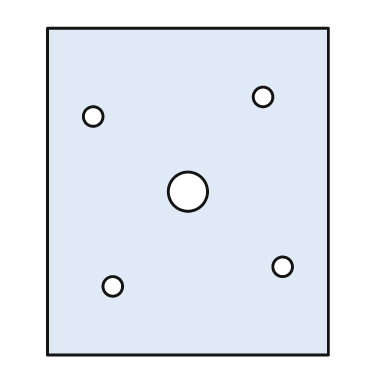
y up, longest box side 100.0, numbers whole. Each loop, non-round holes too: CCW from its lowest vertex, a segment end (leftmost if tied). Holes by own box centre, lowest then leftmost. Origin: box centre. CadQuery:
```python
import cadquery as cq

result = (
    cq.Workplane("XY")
    .moveTo(-43.0, -50.0)
    .lineTo(43.0, -50.0)
    .lineTo(43.0, 50.0)
    .lineTo(-43.0, 50.0)
    .close()
    .moveTo(-23.0, -29.0)
    .circle(3.0)
    .moveTo(29.0, -23.0)
    .circle(3.0)
    .moveTo(0.0, 0.0)
    .circle(6.0)
    .moveTo(-29.0, 23.0)
    .circle(3.0)
    .moveTo(23.0, 29.0)
    .circle(3.0)
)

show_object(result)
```